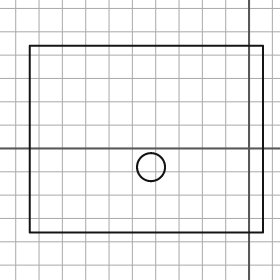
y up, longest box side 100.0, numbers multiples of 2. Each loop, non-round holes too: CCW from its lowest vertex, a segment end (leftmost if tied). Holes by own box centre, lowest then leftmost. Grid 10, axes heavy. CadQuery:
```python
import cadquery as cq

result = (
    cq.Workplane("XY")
    .moveTo(-94.0, -36.0)
    .lineTo(6.0, -36.0)
    .lineTo(6.0, 44.0)
    .lineTo(-94.0, 44.0)
    .close()
    .moveTo(-42.0, -8.0)
    .circle(6.0)
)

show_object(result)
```